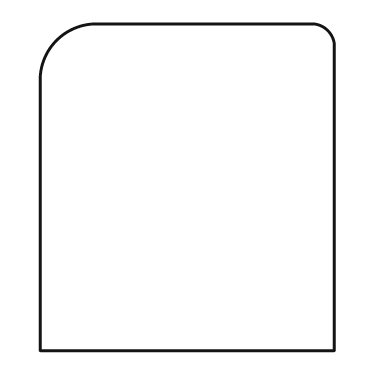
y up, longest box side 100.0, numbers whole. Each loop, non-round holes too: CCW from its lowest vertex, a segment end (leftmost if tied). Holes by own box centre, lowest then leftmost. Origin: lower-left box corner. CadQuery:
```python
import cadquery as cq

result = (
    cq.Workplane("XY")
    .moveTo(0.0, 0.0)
    .lineTo(90.0, 0.0)
    .lineTo(90.0, 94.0)
    .threePointArc((88.0, 98.0), (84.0, 100.0))
    .lineTo(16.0, 100.0)
    .threePointArc((5.0, 95.0), (0.0, 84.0))
    .close()
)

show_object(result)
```